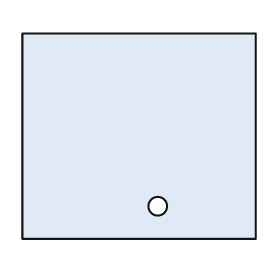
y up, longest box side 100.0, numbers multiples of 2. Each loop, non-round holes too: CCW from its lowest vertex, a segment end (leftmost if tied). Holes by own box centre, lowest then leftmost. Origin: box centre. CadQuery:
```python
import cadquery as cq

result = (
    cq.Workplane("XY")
    .moveTo(-50.0, -44.0)
    .lineTo(50.0, -44.0)
    .lineTo(50.0, 44.0)
    .lineTo(-50.0, 44.0)
    .close()
    .moveTo(8.0, -30.0)
    .circle(4.0)
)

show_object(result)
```